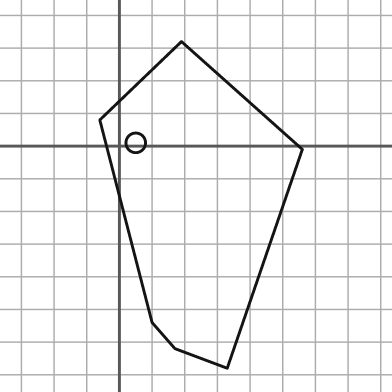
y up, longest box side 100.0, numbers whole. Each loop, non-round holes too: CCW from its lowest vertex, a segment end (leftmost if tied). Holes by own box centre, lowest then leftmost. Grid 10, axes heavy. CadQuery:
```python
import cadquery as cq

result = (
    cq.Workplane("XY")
    .moveTo(33.0, -68.0)
    .lineTo(56.0, -1.0)
    .lineTo(19.0, 32.0)
    .lineTo(-6.0, 8.0)
    .lineTo(10.0, -54.0)
    .lineTo(17.0, -62.0)
    .close()
    .moveTo(5.0, 1.0)
    .circle(3.0)
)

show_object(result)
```